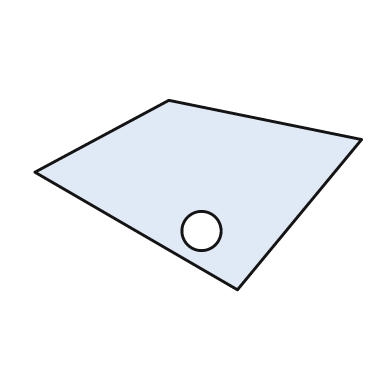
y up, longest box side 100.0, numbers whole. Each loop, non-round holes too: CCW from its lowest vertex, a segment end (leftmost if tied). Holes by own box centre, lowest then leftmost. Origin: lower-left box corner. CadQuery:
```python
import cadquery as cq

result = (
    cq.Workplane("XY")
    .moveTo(62.0, 0.0)
    .lineTo(100.0, 46.0)
    .lineTo(41.0, 58.0)
    .lineTo(0.0, 36.0)
    .close()
    .moveTo(51.0, 18.0)
    .circle(6.0)
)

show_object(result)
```